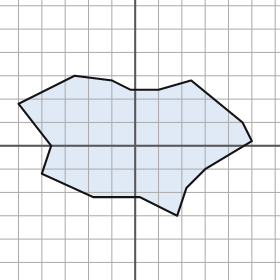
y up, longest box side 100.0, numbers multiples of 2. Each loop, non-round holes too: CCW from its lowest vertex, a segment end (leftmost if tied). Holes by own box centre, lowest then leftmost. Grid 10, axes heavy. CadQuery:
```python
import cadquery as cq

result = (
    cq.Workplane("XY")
    .moveTo(18.0, -30.0)
    .lineTo(22.0, -18.0)
    .lineTo(30.0, -10.0)
    .lineTo(50.0, 2.0)
    .lineTo(46.0, 10.0)
    .lineTo(24.0, 28.0)
    .lineTo(10.0, 24.0)
    .lineTo(-2.0, 24.0)
    .lineTo(-10.0, 28.0)
    .lineTo(-26.0, 30.0)
    .lineTo(-50.0, 18.0)
    .lineTo(-36.0, 0.0)
    .lineTo(-40.0, -12.0)
    .lineTo(-18.0, -22.0)
    .lineTo(2.0, -22.0)
    .close()
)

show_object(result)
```